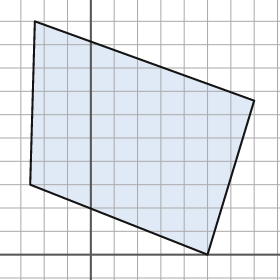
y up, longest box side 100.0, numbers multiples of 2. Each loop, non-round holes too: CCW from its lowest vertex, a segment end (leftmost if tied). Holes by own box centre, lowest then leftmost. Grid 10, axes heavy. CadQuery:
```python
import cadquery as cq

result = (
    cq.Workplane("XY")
    .moveTo(50.0, 0.0)
    .lineTo(70.0, 66.0)
    .lineTo(-24.0, 100.0)
    .lineTo(-26.0, 30.0)
    .close()
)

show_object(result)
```